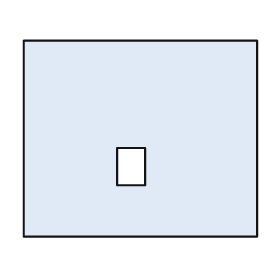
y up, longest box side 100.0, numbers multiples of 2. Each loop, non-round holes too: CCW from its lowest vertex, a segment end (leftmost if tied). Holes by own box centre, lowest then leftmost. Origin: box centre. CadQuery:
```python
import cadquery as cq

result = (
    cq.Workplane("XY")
    .moveTo(-50.0, -42.0)
    .lineTo(50.0, -42.0)
    .lineTo(50.0, 42.0)
    .lineTo(-50.0, 42.0)
    .close()
    .moveTo(-10.0, -20.0)
    .lineTo(2.0, -20.0)
    .lineTo(2.0, -4.0)
    .lineTo(-10.0, -4.0)
    .close()
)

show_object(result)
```